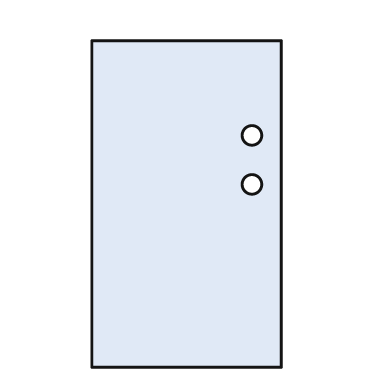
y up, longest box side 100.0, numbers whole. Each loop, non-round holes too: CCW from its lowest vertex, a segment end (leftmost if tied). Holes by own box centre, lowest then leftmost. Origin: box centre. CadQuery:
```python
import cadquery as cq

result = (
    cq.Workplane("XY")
    .moveTo(-29.0, -50.0)
    .lineTo(29.0, -50.0)
    .lineTo(29.0, 50.0)
    .lineTo(-29.0, 50.0)
    .close()
    .moveTo(20.0, 6.0)
    .circle(3.0)
    .moveTo(20.0, 21.0)
    .circle(3.0)
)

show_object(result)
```